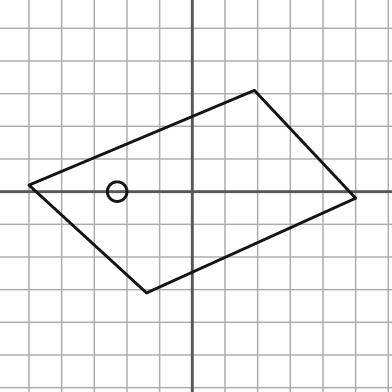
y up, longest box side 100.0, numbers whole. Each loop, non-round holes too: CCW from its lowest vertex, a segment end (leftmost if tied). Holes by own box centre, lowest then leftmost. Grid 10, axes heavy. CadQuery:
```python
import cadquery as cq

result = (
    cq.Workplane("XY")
    .moveTo(-14.0, -31.0)
    .lineTo(50.0, -2.0)
    .lineTo(19.0, 31.0)
    .lineTo(-50.0, 2.0)
    .close()
    .moveTo(-23.0, 0.0)
    .circle(3.0)
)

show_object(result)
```